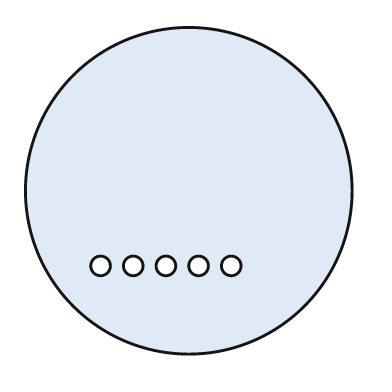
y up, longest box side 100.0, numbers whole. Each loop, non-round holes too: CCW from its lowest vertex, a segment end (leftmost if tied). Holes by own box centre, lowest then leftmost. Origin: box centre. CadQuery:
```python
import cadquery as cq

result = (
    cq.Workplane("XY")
    .moveTo(0.0, 0.0)
    .circle(50.0)
    .moveTo(-27.0, -23.0)
    .circle(3.0)
    .moveTo(-17.0, -23.0)
    .circle(3.0)
    .moveTo(-7.0, -23.0)
    .circle(3.0)
    .moveTo(3.0, -23.0)
    .circle(3.0)
    .moveTo(13.0, -23.0)
    .circle(3.0)
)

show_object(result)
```